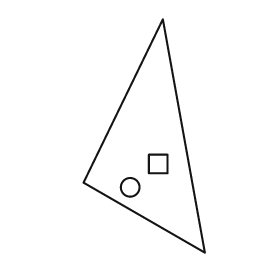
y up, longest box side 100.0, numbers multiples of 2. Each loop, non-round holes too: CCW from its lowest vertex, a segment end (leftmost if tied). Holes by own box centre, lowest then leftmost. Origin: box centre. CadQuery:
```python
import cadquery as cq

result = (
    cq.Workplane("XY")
    .moveTo(26.0, -50.0)
    .lineTo(8.0, 50.0)
    .lineTo(-26.0, -20.0)
    .close()
    .moveTo(-6.0, -22.0)
    .circle(4.0)
    .moveTo(2.0, -16.0)
    .lineTo(10.0, -16.0)
    .lineTo(10.0, -8.0)
    .lineTo(2.0, -8.0)
    .close()
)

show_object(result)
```